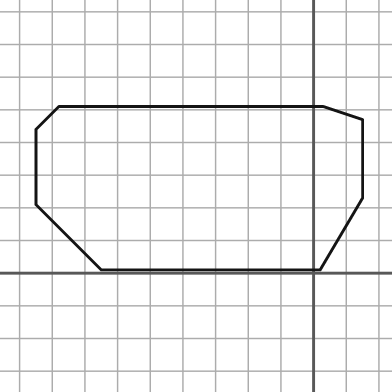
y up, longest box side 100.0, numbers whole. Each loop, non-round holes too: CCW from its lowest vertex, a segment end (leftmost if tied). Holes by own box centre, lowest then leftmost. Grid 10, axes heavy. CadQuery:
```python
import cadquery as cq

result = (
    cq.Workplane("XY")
    .moveTo(-65.0, 1.0)
    .lineTo(2.0, 1.0)
    .lineTo(15.0, 23.0)
    .lineTo(15.0, 47.0)
    .lineTo(3.0, 51.0)
    .lineTo(-78.0, 51.0)
    .lineTo(-85.0, 44.0)
    .lineTo(-85.0, 21.0)
    .close()
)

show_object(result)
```